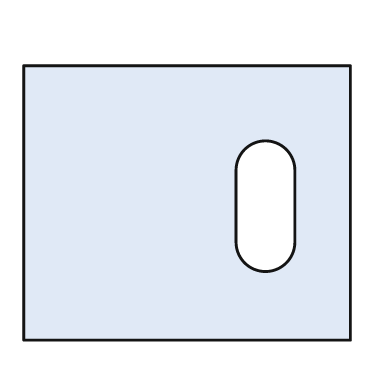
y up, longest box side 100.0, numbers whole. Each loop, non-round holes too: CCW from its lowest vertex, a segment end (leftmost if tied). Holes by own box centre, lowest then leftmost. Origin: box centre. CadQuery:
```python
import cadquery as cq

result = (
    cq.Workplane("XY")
    .moveTo(-50.0, -42.0)
    .lineTo(50.0, -42.0)
    .lineTo(50.0, 42.0)
    .lineTo(-50.0, 42.0)
    .close()
    .moveTo(15.0, -12.0)
    .threePointArc((24.0, -21.0), (33.0, -12.0))
    .lineTo(33.0, 10.0)
    .threePointArc((24.0, 19.0), (15.0, 10.0))
    .close()
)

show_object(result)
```